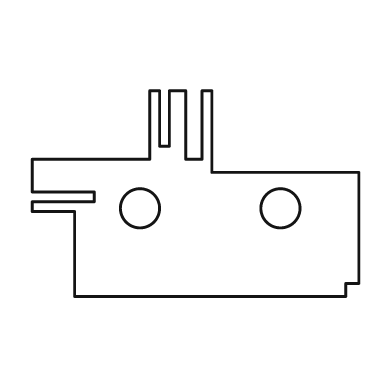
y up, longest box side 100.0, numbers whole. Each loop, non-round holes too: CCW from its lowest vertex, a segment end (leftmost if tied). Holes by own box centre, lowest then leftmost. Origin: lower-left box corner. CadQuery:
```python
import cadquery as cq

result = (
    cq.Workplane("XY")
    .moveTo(13.0, 0.0)
    .lineTo(96.0, 0.0)
    .lineTo(96.0, 4.0)
    .lineTo(100.0, 4.0)
    .lineTo(100.0, 38.0)
    .lineTo(55.0, 38.0)
    .lineTo(55.0, 63.0)
    .lineTo(52.0, 63.0)
    .lineTo(52.0, 42.0)
    .lineTo(47.0, 42.0)
    .lineTo(47.0, 63.0)
    .lineTo(42.0, 63.0)
    .lineTo(42.0, 46.0)
    .lineTo(39.0, 46.0)
    .lineTo(39.0, 63.0)
    .lineTo(36.0, 63.0)
    .lineTo(36.0, 42.0)
    .lineTo(0.0, 42.0)
    .lineTo(0.0, 32.0)
    .lineTo(19.0, 32.0)
    .lineTo(19.0, 29.0)
    .lineTo(0.0, 29.0)
    .lineTo(0.0, 26.0)
    .lineTo(13.0, 26.0)
    .close()
    .moveTo(33.0, 27.0)
    .circle(6.0)
    .moveTo(76.0, 27.0)
    .circle(6.0)
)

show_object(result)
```